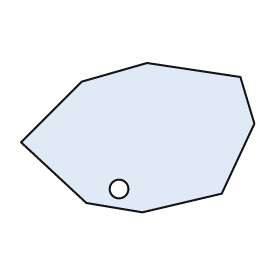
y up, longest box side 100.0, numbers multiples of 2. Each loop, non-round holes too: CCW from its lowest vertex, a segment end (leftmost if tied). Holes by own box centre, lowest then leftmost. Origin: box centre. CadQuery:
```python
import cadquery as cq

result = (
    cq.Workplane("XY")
    .moveTo(2.0, -32.0)
    .lineTo(36.0, -24.0)
    .lineTo(50.0, 6.0)
    .lineTo(44.0, 26.0)
    .lineTo(4.0, 32.0)
    .lineTo(-24.0, 24.0)
    .lineTo(-50.0, -2.0)
    .lineTo(-22.0, -28.0)
    .close()
    .moveTo(-8.0, -22.0)
    .circle(4.0)
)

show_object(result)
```